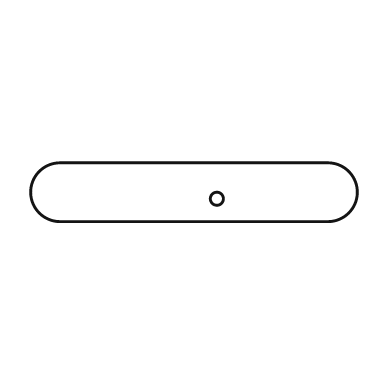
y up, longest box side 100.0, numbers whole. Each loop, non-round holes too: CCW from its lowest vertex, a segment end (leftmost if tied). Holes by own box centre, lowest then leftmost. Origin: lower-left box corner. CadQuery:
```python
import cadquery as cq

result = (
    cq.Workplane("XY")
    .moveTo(9.0, 0.0)
    .lineTo(91.0, 0.0)
    .threePointArc((100.0, 9.0), (91.0, 18.0))
    .lineTo(9.0, 18.0)
    .threePointArc((0.0, 9.0), (9.0, 0.0))
    .close()
    .moveTo(57.0, 7.0)
    .circle(2.0)
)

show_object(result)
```